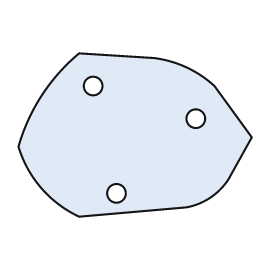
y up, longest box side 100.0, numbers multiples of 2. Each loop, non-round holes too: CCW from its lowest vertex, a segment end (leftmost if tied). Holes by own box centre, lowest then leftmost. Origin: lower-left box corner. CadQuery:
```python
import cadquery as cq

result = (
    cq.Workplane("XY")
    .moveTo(26.0, 0.0)
    .lineTo(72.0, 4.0)
    .threePointArc((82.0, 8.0), (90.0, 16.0))
    .lineTo(100.0, 34.0)
    .lineTo(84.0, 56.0)
    .threePointArc((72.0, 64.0), (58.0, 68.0))
    .lineTo(26.0, 70.0)
    .threePointArc((10.0, 52.0), (0.0, 30.0))
    .threePointArc((10.0, 12.0), (26.0, 0.0))
    .close()
    .moveTo(42.0, 10.0)
    .circle(4.0)
    .moveTo(76.0, 42.0)
    .circle(4.0)
    .moveTo(32.0, 56.0)
    .circle(4.0)
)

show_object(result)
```